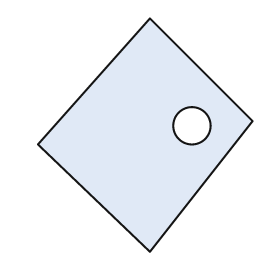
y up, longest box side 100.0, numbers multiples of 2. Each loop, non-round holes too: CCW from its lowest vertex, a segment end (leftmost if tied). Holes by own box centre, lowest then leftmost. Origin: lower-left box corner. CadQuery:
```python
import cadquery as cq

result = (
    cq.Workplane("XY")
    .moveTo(48.0, 0.0)
    .lineTo(92.0, 56.0)
    .lineTo(48.0, 100.0)
    .lineTo(0.0, 46.0)
    .close()
    .moveTo(66.0, 54.0)
    .circle(8.0)
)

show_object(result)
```